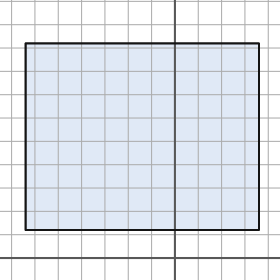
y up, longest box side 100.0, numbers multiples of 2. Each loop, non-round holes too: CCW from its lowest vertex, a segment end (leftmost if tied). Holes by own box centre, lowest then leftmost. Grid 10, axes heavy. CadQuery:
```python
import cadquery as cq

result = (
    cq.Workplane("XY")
    .moveTo(-64.0, 12.0)
    .lineTo(36.0, 12.0)
    .lineTo(36.0, 92.0)
    .lineTo(-64.0, 92.0)
    .close()
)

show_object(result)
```